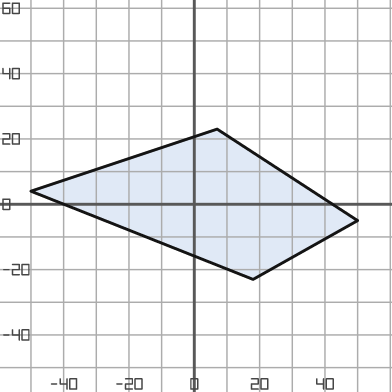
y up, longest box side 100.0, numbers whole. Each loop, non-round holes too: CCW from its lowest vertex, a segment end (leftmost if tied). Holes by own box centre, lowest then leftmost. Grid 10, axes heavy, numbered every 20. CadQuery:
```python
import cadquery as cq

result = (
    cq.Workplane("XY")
    .moveTo(18.0, -23.0)
    .lineTo(50.0, -5.0)
    .lineTo(7.0, 23.0)
    .lineTo(-50.0, 4.0)
    .close()
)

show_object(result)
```